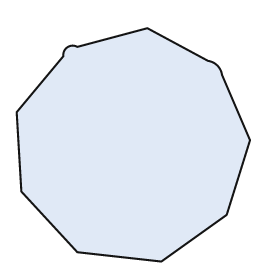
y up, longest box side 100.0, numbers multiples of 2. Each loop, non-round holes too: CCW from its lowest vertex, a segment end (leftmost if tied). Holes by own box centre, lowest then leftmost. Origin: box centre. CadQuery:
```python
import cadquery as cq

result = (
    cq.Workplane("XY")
    .moveTo(12.0, -50.0)
    .lineTo(40.0, -30.0)
    .lineTo(50.0, 2.0)
    .lineTo(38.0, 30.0)
    .threePointArc((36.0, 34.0), (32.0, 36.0))
    .lineTo(6.0, 50.0)
    .lineTo(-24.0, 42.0)
    .threePointArc((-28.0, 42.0), (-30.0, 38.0))
    .lineTo(-50.0, 14.0)
    .lineTo(-48.0, -20.0)
    .lineTo(-24.0, -46.0)
    .close()
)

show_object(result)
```